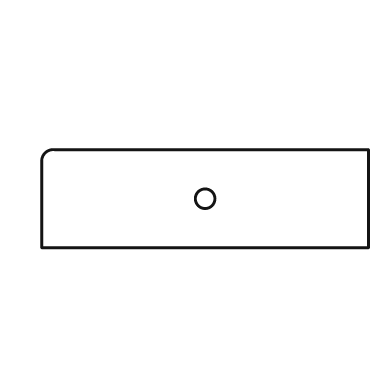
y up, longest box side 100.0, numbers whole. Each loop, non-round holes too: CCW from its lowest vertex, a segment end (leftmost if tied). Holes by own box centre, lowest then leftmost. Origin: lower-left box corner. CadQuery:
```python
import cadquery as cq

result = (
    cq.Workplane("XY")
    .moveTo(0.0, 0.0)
    .lineTo(100.0, 0.0)
    .lineTo(100.0, 30.0)
    .lineTo(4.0, 30.0)
    .threePointArc((1.0, 29.0), (0.0, 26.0))
    .close()
    .moveTo(50.0, 15.0)
    .circle(3.0)
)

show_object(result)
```